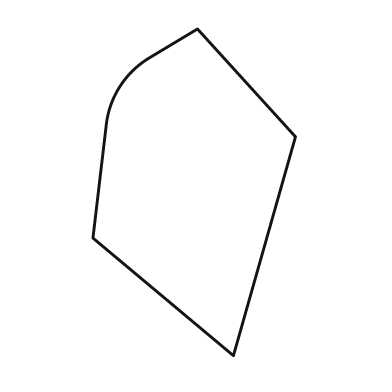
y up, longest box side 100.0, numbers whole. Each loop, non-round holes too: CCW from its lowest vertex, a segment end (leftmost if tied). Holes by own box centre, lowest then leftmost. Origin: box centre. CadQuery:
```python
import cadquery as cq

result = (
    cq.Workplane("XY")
    .moveTo(12.0, -50.0)
    .lineTo(31.0, 17.0)
    .lineTo(1.0, 50.0)
    .lineTo(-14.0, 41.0)
    .threePointArc((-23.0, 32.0), (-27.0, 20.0))
    .lineTo(-31.0, -14.0)
    .close()
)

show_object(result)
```